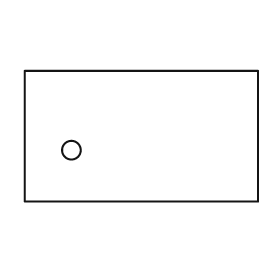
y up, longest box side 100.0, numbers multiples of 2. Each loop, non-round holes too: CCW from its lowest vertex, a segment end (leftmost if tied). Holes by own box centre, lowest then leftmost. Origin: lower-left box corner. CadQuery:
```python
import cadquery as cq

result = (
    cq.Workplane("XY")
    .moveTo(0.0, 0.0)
    .lineTo(100.0, 0.0)
    .lineTo(100.0, 56.0)
    .lineTo(0.0, 56.0)
    .close()
    .moveTo(20.0, 22.0)
    .circle(4.0)
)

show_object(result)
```